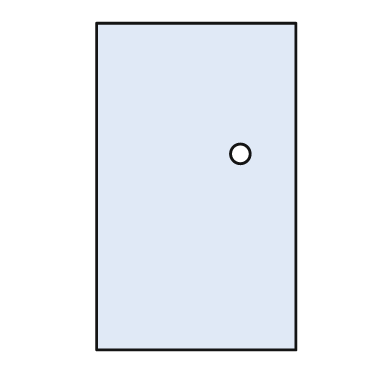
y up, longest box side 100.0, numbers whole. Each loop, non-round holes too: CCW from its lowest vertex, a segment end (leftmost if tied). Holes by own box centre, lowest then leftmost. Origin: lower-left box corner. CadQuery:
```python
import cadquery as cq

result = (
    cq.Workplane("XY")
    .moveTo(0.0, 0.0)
    .lineTo(61.0, 0.0)
    .lineTo(61.0, 100.0)
    .lineTo(0.0, 100.0)
    .close()
    .moveTo(44.0, 60.0)
    .circle(3.0)
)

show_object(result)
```